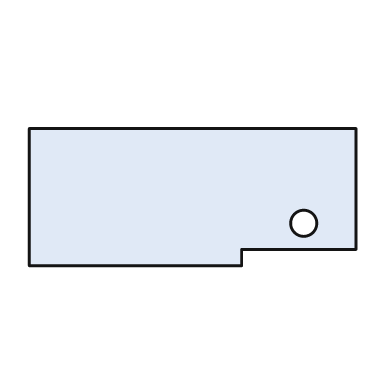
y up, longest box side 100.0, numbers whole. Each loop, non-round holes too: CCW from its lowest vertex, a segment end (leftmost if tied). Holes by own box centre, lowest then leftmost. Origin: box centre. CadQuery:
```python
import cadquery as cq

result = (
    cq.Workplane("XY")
    .moveTo(-50.0, -21.0)
    .lineTo(15.0, -21.0)
    .lineTo(15.0, -16.0)
    .lineTo(50.0, -16.0)
    .lineTo(50.0, 21.0)
    .lineTo(-50.0, 21.0)
    .close()
    .moveTo(34.0, -8.0)
    .circle(4.0)
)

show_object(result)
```